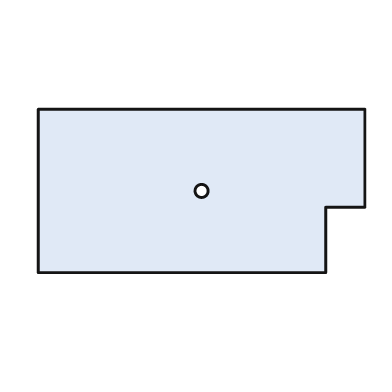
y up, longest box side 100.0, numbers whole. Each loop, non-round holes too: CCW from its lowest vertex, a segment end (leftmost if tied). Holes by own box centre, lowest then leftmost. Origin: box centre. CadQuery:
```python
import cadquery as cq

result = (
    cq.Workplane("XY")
    .moveTo(-50.0, -25.0)
    .lineTo(38.0, -25.0)
    .lineTo(38.0, -5.0)
    .lineTo(50.0, -5.0)
    .lineTo(50.0, 25.0)
    .lineTo(-50.0, 25.0)
    .close()
    .moveTo(0.0, 0.0)
    .circle(2.0)
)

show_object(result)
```